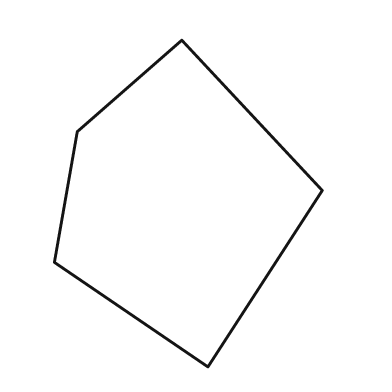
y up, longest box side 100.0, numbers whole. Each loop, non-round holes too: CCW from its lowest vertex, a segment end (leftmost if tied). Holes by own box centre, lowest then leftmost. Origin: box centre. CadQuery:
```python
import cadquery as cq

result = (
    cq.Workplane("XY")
    .moveTo(6.0, -50.0)
    .lineTo(41.0, 4.0)
    .lineTo(-2.0, 50.0)
    .lineTo(-34.0, 22.0)
    .lineTo(-41.0, -18.0)
    .close()
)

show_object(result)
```